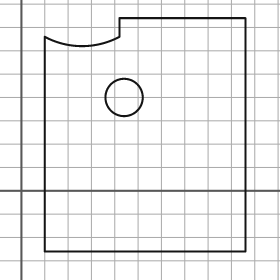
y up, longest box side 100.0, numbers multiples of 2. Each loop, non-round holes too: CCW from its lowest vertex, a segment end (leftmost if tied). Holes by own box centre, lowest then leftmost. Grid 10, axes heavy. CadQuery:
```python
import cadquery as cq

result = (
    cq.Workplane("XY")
    .moveTo(10.0, -26.0)
    .lineTo(96.0, -26.0)
    .lineTo(96.0, 74.0)
    .lineTo(42.0, 74.0)
    .lineTo(42.0, 66.0)
    .threePointArc((26.0, 62.0), (10.0, 66.0))
    .close()
    .moveTo(44.0, 40.0)
    .circle(8.0)
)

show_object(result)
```